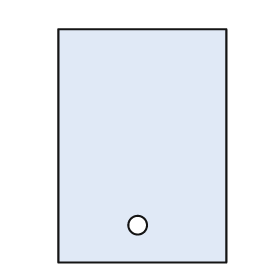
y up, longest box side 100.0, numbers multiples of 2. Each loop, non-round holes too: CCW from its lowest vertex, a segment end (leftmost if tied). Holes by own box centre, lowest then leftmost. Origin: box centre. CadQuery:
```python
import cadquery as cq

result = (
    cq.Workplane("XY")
    .moveTo(-36.0, -50.0)
    .lineTo(36.0, -50.0)
    .lineTo(36.0, 50.0)
    .lineTo(-36.0, 50.0)
    .close()
    .moveTo(-2.0, -34.0)
    .circle(4.0)
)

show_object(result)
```